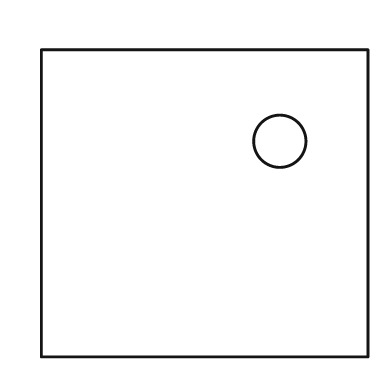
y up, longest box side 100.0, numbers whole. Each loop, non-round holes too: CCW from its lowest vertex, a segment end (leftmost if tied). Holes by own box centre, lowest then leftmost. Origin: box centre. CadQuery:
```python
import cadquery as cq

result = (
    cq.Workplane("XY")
    .moveTo(-50.0, -47.0)
    .lineTo(50.0, -47.0)
    .lineTo(50.0, 47.0)
    .lineTo(-50.0, 47.0)
    .close()
    .moveTo(23.0, 19.0)
    .circle(8.0)
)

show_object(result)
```